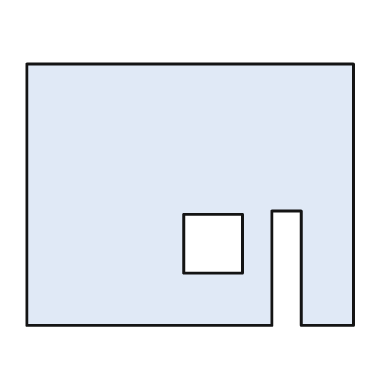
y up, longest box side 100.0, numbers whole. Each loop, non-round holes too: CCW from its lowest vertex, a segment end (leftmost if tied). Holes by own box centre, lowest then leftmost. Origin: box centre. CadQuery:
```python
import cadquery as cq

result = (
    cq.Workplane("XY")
    .moveTo(-50.0, -40.0)
    .lineTo(25.0, -40.0)
    .lineTo(25.0, -5.0)
    .lineTo(34.0, -5.0)
    .lineTo(34.0, -40.0)
    .lineTo(50.0, -40.0)
    .lineTo(50.0, 40.0)
    .lineTo(-50.0, 40.0)
    .close()
    .moveTo(-2.0, -24.0)
    .lineTo(16.0, -24.0)
    .lineTo(16.0, -6.0)
    .lineTo(-2.0, -6.0)
    .close()
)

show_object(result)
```